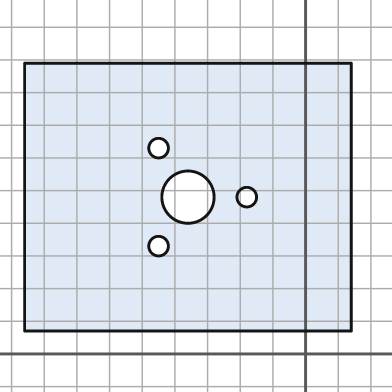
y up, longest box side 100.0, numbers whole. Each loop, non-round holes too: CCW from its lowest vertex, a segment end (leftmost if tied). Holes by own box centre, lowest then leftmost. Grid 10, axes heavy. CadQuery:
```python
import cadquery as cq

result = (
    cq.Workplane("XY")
    .moveTo(-86.0, 7.0)
    .lineTo(14.0, 7.0)
    .lineTo(14.0, 89.0)
    .lineTo(-86.0, 89.0)
    .close()
    .moveTo(-45.0, 33.0)
    .circle(3.0)
    .moveTo(-36.0, 48.0)
    .circle(8.0)
    .moveTo(-18.0, 48.0)
    .circle(3.0)
    .moveTo(-45.0, 63.0)
    .circle(3.0)
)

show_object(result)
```